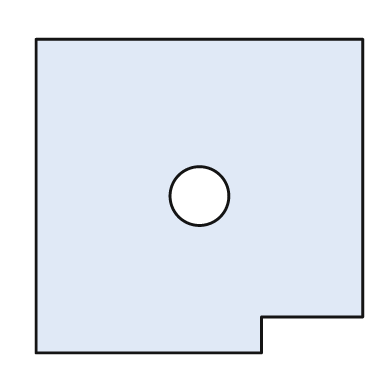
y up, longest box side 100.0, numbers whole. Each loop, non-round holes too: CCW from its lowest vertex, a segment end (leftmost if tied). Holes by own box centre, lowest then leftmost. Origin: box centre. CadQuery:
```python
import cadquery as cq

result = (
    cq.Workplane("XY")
    .moveTo(-50.0, -48.0)
    .lineTo(19.0, -48.0)
    .lineTo(19.0, -37.0)
    .lineTo(50.0, -37.0)
    .lineTo(50.0, 48.0)
    .lineTo(-50.0, 48.0)
    .close()
    .moveTo(0.0, 0.0)
    .circle(9.0)
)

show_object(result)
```